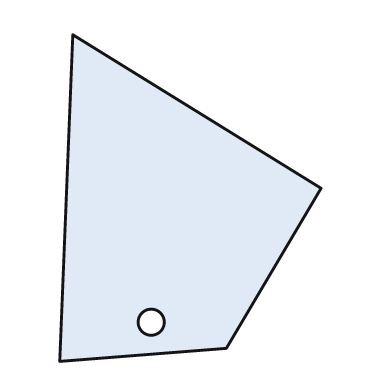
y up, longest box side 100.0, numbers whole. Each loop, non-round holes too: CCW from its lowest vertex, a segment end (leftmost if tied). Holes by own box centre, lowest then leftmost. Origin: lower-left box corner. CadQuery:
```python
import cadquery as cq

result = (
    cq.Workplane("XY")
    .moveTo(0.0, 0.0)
    .lineTo(51.0, 4.0)
    .lineTo(80.0, 53.0)
    .lineTo(4.0, 100.0)
    .close()
    .moveTo(28.0, 12.0)
    .circle(4.0)
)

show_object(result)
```